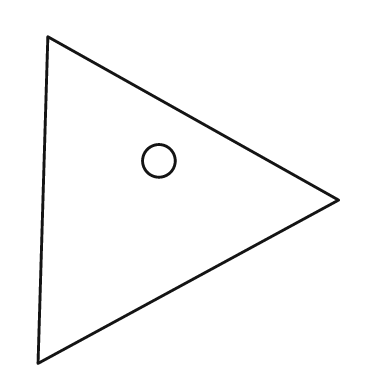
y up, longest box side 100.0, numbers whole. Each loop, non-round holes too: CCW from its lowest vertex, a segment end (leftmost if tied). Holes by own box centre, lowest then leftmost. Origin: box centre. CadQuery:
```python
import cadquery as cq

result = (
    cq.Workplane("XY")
    .moveTo(-46.0, -50.0)
    .lineTo(46.0, 0.0)
    .lineTo(-43.0, 50.0)
    .close()
    .moveTo(-9.0, 12.0)
    .circle(5.0)
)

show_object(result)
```